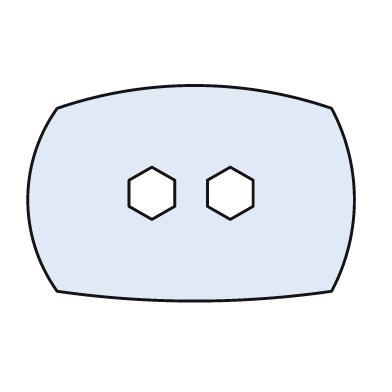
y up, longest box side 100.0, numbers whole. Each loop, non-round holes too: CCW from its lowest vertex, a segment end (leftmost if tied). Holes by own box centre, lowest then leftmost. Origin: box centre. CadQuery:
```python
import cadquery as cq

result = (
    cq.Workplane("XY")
    .moveTo(-41.0, -30.0)
    .threePointArc((1.0, -33.0), (43.0, -30.0))
    .threePointArc((50.0, -2.0), (43.0, 26.0))
    .threePointArc((1.0, 33.0), (-41.0, 26.0))
    .threePointArc((-50.0, -2.0), (-41.0, -30.0))
    .close()
    .moveTo(-12.0, -8.0)
    .lineTo(-5.0, -4.0)
    .lineTo(-5.0, 4.0)
    .lineTo(-12.0, 8.0)
    .lineTo(-19.0, 4.0)
    .lineTo(-19.0, -4.0)
    .close()
    .moveTo(12.0, -8.0)
    .lineTo(19.0, -4.0)
    .lineTo(19.0, 4.0)
    .lineTo(12.0, 8.0)
    .lineTo(5.0, 4.0)
    .lineTo(5.0, -4.0)
    .close()
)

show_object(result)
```